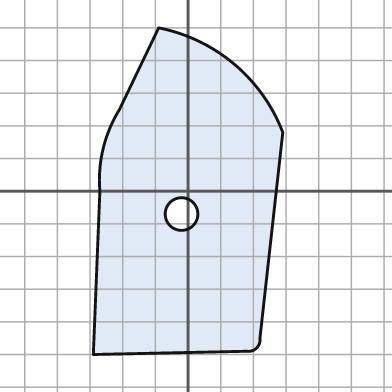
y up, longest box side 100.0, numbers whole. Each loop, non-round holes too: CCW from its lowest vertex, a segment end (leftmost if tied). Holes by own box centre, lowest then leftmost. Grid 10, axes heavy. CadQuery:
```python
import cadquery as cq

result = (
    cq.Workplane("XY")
    .moveTo(-29.0, -50.0)
    .lineTo(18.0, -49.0)
    .threePointArc((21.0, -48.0), (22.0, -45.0))
    .lineTo(29.0, 18.0)
    .threePointArc((14.0, 39.0), (-9.0, 50.0))
    .lineTo(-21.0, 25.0)
    .threePointArc((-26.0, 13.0), (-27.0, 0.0))
    .close()
    .moveTo(-2.0, -7.0)
    .circle(5.0)
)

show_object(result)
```